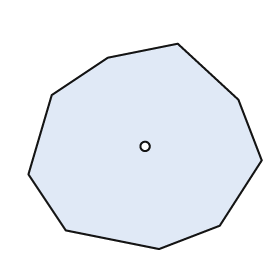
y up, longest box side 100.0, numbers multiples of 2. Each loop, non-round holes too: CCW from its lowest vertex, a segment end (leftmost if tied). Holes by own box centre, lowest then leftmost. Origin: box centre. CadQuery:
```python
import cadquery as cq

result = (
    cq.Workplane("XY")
    .moveTo(6.0, -44.0)
    .lineTo(32.0, -34.0)
    .lineTo(50.0, -6.0)
    .lineTo(40.0, 20.0)
    .lineTo(14.0, 44.0)
    .lineTo(-16.0, 38.0)
    .lineTo(-40.0, 22.0)
    .lineTo(-50.0, -12.0)
    .lineTo(-34.0, -36.0)
    .close()
    .moveTo(0.0, 0.0)
    .circle(2.0)
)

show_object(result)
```